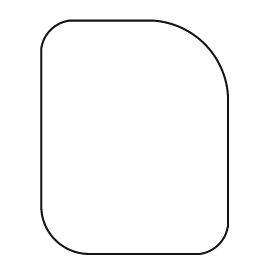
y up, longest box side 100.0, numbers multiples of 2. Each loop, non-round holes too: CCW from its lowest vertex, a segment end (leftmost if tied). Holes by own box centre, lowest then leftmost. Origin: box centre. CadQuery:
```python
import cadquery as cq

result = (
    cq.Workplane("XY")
    .moveTo(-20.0, -50.0)
    .lineTo(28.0, -50.0)
    .threePointArc((36.0, -46.0), (40.0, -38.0))
    .lineTo(40.0, 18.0)
    .threePointArc((30.0, 40.0), (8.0, 50.0))
    .lineTo(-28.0, 50.0)
    .threePointArc((-36.0, 46.0), (-40.0, 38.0))
    .lineTo(-40.0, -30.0)
    .threePointArc((-34.0, -44.0), (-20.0, -50.0))
    .close()
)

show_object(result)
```